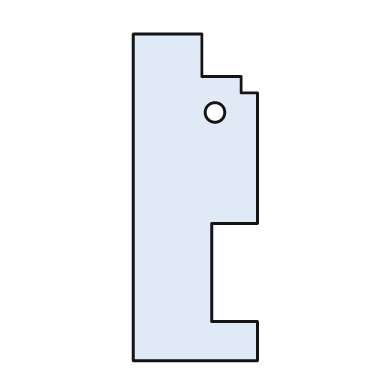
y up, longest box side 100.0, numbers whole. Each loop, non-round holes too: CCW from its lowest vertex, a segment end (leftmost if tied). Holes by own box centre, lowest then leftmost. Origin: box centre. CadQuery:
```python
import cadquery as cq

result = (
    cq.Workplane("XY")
    .moveTo(-19.0, -50.0)
    .lineTo(19.0, -50.0)
    .lineTo(19.0, -38.0)
    .lineTo(5.0, -38.0)
    .lineTo(5.0, -8.0)
    .lineTo(19.0, -8.0)
    .lineTo(19.0, 32.0)
    .lineTo(14.0, 32.0)
    .lineTo(14.0, 37.0)
    .lineTo(2.0, 37.0)
    .lineTo(2.0, 50.0)
    .lineTo(-19.0, 50.0)
    .close()
    .moveTo(6.0, 26.0)
    .circle(3.0)
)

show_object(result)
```